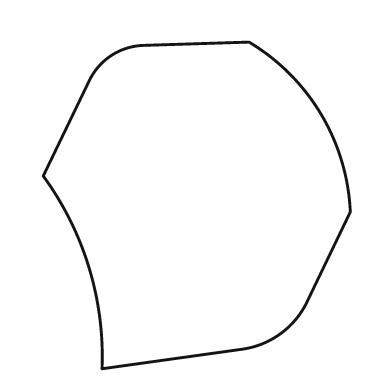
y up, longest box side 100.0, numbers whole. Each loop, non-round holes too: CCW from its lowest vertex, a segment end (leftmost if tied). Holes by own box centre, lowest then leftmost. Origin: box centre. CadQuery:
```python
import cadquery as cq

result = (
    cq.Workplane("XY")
    .moveTo(-29.0, -50.0)
    .lineTo(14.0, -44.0)
    .threePointArc((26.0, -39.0), (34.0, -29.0))
    .lineTo(47.0, -2.0)
    .threePointArc((38.0, 28.0), (16.0, 50.0))
    .lineTo(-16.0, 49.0)
    .threePointArc((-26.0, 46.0), (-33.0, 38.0))
    .lineTo(-47.0, 9.0)
    .threePointArc((-33.0, -19.0), (-29.0, -50.0))
    .close()
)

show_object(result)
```